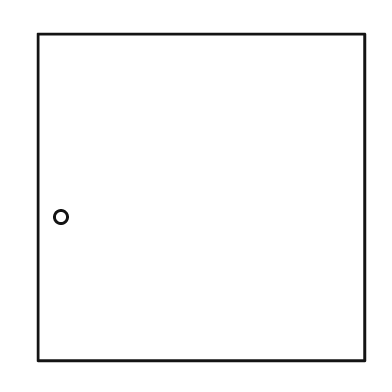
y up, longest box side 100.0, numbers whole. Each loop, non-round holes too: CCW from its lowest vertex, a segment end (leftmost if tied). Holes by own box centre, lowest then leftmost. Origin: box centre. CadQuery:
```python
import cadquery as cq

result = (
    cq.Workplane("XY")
    .moveTo(-50.0, -50.0)
    .lineTo(50.0, -50.0)
    .lineTo(50.0, 50.0)
    .lineTo(-50.0, 50.0)
    .close()
    .moveTo(-43.0, -6.0)
    .circle(2.0)
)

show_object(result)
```